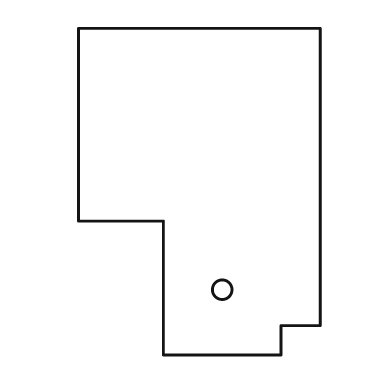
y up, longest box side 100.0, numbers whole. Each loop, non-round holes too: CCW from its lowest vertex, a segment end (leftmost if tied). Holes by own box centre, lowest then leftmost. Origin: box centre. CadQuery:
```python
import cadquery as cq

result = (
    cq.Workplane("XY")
    .moveTo(-11.0, -50.0)
    .lineTo(25.0, -50.0)
    .lineTo(25.0, -41.0)
    .lineTo(37.0, -41.0)
    .lineTo(37.0, 50.0)
    .lineTo(-37.0, 50.0)
    .lineTo(-37.0, -9.0)
    .lineTo(-11.0, -9.0)
    .close()
    .moveTo(7.0, -30.0)
    .circle(3.0)
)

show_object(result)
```